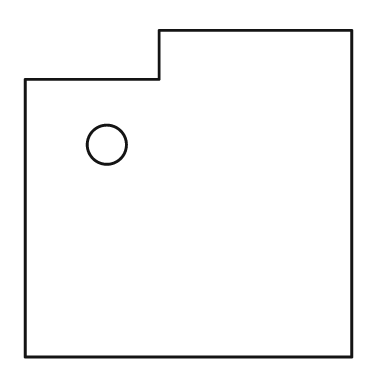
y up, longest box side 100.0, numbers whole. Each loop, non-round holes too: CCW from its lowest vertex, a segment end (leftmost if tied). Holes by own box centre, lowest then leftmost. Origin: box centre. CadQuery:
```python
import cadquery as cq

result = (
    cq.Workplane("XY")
    .moveTo(-50.0, -50.0)
    .lineTo(50.0, -50.0)
    .lineTo(50.0, 50.0)
    .lineTo(-9.0, 50.0)
    .lineTo(-9.0, 35.0)
    .lineTo(-50.0, 35.0)
    .close()
    .moveTo(-25.0, 15.0)
    .circle(6.0)
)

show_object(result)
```